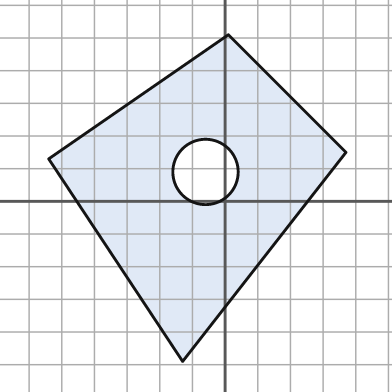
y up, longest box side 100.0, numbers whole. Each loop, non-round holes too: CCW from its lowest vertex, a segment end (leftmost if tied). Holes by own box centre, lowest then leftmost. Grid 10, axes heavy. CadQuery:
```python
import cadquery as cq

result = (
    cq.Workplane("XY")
    .moveTo(-13.0, -49.0)
    .lineTo(37.0, 15.0)
    .lineTo(1.0, 51.0)
    .lineTo(-54.0, 13.0)
    .close()
    .moveTo(-6.0, 9.0)
    .circle(10.0)
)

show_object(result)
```